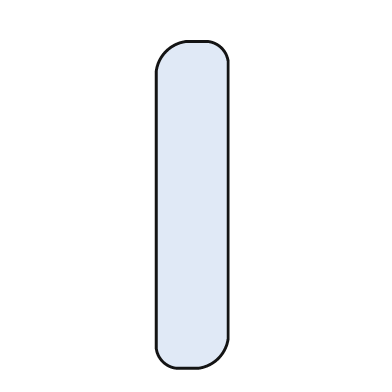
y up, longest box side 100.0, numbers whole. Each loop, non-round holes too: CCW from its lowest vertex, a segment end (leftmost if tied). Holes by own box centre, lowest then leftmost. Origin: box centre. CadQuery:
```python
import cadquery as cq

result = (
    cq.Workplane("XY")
    .moveTo(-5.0, -50.0)
    .lineTo(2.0, -50.0)
    .threePointArc((8.0, -47.0), (11.0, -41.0))
    .lineTo(11.0, 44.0)
    .threePointArc((9.0, 48.0), (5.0, 50.0))
    .lineTo(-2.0, 50.0)
    .threePointArc((-8.0, 47.0), (-11.0, 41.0))
    .lineTo(-11.0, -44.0)
    .threePointArc((-9.0, -48.0), (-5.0, -50.0))
    .close()
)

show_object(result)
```